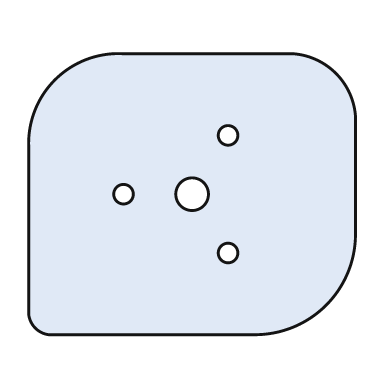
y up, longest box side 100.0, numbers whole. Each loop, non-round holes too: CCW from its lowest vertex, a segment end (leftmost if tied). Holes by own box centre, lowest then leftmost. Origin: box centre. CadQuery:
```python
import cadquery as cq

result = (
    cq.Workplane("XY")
    .moveTo(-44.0, -43.0)
    .lineTo(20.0, -43.0)
    .threePointArc((41.0, -34.0), (50.0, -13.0))
    .lineTo(50.0, 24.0)
    .threePointArc((44.0, 37.0), (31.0, 43.0))
    .lineTo(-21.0, 43.0)
    .threePointArc((-42.0, 35.0), (-50.0, 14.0))
    .lineTo(-50.0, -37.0)
    .threePointArc((-48.0, -41.0), (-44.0, -43.0))
    .close()
    .moveTo(11.0, -18.0)
    .circle(3.0)
    .moveTo(-21.0, 0.0)
    .circle(3.0)
    .moveTo(0.0, 0.0)
    .circle(5.0)
    .moveTo(11.0, 18.0)
    .circle(3.0)
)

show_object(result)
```